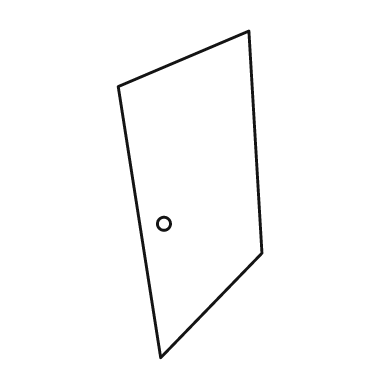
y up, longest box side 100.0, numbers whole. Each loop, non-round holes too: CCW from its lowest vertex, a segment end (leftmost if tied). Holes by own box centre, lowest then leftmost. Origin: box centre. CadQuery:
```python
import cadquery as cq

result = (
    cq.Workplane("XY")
    .moveTo(-9.0, -50.0)
    .lineTo(22.0, -18.0)
    .lineTo(18.0, 50.0)
    .lineTo(-22.0, 33.0)
    .close()
    .moveTo(-8.0, -9.0)
    .circle(2.0)
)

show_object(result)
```